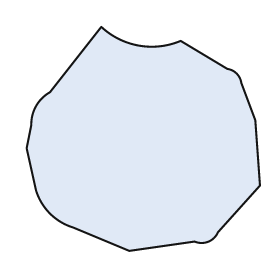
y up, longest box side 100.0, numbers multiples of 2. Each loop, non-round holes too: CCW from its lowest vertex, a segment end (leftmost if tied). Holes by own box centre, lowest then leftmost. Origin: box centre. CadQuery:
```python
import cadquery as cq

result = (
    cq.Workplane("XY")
    .moveTo(-6.0, -48.0)
    .lineTo(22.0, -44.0)
    .threePointArc((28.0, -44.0), (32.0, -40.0))
    .lineTo(50.0, -20.0)
    .lineTo(48.0, 8.0)
    .lineTo(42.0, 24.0)
    .threePointArc((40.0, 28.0), (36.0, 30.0))
    .lineTo(16.0, 42.0)
    .threePointArc((-2.0, 40.0), (-18.0, 48.0))
    .lineTo(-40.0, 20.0)
    .threePointArc((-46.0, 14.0), (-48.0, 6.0))
    .lineTo(-50.0, -4.0)
    .lineTo(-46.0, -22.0)
    .threePointArc((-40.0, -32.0), (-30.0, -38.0))
    .close()
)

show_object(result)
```